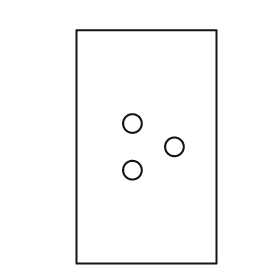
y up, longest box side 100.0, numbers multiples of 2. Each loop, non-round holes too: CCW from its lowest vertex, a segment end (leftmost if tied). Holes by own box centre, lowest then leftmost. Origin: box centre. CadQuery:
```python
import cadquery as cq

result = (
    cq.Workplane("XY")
    .moveTo(-30.0, -50.0)
    .lineTo(30.0, -50.0)
    .lineTo(30.0, 50.0)
    .lineTo(-30.0, 50.0)
    .close()
    .moveTo(-6.0, -10.0)
    .circle(4.0)
    .moveTo(12.0, 0.0)
    .circle(4.0)
    .moveTo(-6.0, 10.0)
    .circle(4.0)
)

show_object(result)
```